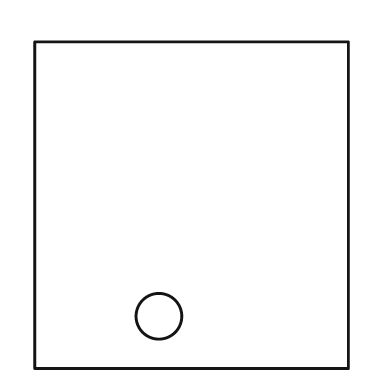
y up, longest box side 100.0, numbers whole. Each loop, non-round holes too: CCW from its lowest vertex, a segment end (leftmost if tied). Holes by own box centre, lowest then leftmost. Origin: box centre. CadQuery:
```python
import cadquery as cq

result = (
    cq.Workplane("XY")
    .moveTo(-48.0, -50.0)
    .lineTo(48.0, -50.0)
    .lineTo(48.0, 50.0)
    .lineTo(-48.0, 50.0)
    .close()
    .moveTo(-10.0, -34.0)
    .circle(7.0)
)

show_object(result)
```